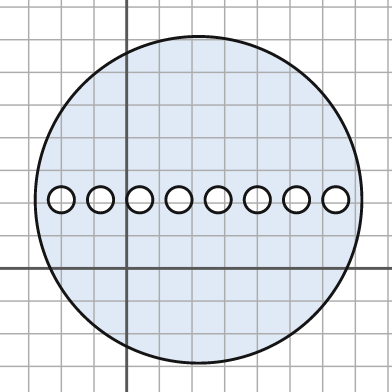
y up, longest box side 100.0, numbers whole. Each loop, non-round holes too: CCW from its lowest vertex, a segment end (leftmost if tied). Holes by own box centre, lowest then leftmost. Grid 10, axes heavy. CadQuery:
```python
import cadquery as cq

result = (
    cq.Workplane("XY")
    .moveTo(22.0, 21.0)
    .circle(50.0)
    .moveTo(-20.0, 21.0)
    .circle(4.0)
    .moveTo(-8.0, 21.0)
    .circle(4.0)
    .moveTo(4.0, 21.0)
    .circle(4.0)
    .moveTo(16.0, 21.0)
    .circle(4.0)
    .moveTo(28.0, 21.0)
    .circle(4.0)
    .moveTo(40.0, 21.0)
    .circle(4.0)
    .moveTo(52.0, 21.0)
    .circle(4.0)
    .moveTo(64.0, 21.0)
    .circle(4.0)
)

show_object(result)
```